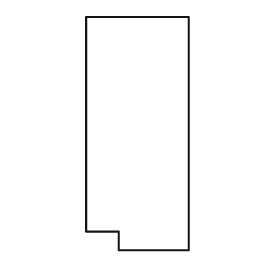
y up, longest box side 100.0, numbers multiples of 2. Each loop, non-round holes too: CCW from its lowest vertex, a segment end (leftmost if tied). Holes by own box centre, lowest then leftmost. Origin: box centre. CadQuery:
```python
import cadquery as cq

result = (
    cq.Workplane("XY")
    .moveTo(-8.0, -50.0)
    .lineTo(22.0, -50.0)
    .lineTo(22.0, 50.0)
    .lineTo(-22.0, 50.0)
    .lineTo(-22.0, -42.0)
    .lineTo(-8.0, -42.0)
    .close()
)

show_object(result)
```